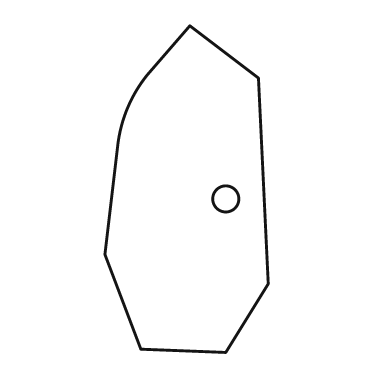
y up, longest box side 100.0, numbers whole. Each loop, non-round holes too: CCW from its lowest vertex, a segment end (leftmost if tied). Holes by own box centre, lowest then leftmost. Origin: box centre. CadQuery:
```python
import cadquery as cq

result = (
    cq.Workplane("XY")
    .moveTo(12.0, -50.0)
    .lineTo(25.0, -29.0)
    .lineTo(22.0, 34.0)
    .lineTo(1.0, 50.0)
    .lineTo(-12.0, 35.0)
    .threePointArc((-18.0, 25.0), (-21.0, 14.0))
    .lineTo(-25.0, -20.0)
    .lineTo(-14.0, -49.0)
    .close()
    .moveTo(12.0, -3.0)
    .circle(4.0)
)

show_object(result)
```